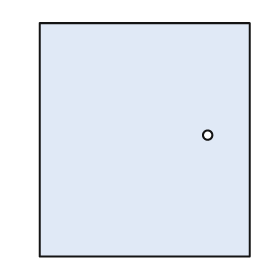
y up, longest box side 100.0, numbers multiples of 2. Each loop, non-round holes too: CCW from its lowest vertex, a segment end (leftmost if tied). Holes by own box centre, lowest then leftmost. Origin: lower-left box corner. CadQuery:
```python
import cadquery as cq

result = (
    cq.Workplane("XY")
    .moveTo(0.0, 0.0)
    .lineTo(90.0, 0.0)
    .lineTo(90.0, 100.0)
    .lineTo(0.0, 100.0)
    .close()
    .moveTo(72.0, 52.0)
    .circle(2.0)
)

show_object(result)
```